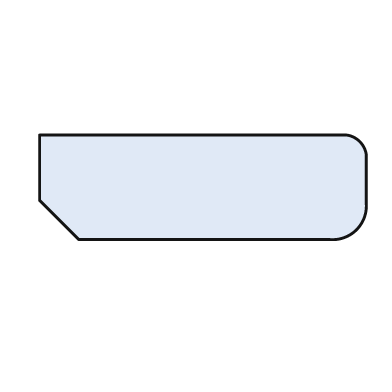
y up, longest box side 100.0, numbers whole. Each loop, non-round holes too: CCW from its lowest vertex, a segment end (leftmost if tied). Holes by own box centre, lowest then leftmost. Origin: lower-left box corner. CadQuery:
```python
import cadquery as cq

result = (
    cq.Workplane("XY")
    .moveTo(12.0, 0.0)
    .lineTo(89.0, 0.0)
    .threePointArc((97.0, 3.0), (100.0, 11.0))
    .lineTo(100.0, 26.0)
    .threePointArc((98.0, 30.0), (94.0, 32.0))
    .lineTo(0.0, 32.0)
    .lineTo(0.0, 12.0)
    .close()
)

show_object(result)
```